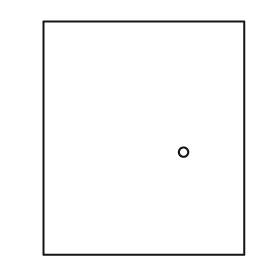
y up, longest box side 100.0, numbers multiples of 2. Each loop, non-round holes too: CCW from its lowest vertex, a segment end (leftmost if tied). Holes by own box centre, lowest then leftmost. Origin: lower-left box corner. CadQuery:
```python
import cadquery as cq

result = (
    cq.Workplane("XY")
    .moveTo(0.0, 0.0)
    .lineTo(86.0, 0.0)
    .lineTo(86.0, 100.0)
    .lineTo(0.0, 100.0)
    .close()
    .moveTo(60.0, 44.0)
    .circle(2.0)
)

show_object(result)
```